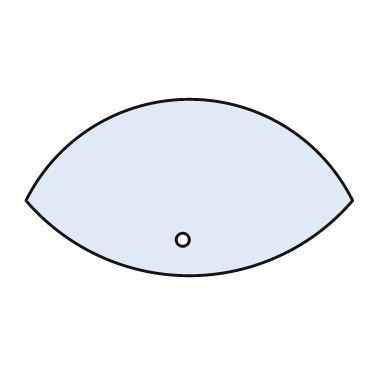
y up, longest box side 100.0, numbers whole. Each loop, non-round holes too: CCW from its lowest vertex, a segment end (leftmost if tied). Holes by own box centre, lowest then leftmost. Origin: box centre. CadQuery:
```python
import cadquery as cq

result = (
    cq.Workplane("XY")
    .moveTo(-50.0, -4.0)
    .threePointArc((0.0, -27.0), (50.0, -4.0))
    .threePointArc((0.0, 27.0), (-50.0, -4.0))
    .close()
    .moveTo(-2.0, -16.0)
    .circle(2.0)
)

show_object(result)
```